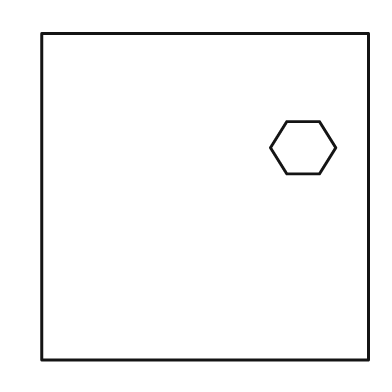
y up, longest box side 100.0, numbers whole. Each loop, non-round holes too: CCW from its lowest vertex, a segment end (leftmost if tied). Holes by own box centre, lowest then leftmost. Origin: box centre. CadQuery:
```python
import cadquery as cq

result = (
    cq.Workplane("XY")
    .moveTo(-50.0, -50.0)
    .lineTo(50.0, -50.0)
    .lineTo(50.0, 50.0)
    .lineTo(-50.0, 50.0)
    .close()
    .moveTo(25.0, 7.0)
    .lineTo(35.0, 7.0)
    .lineTo(40.0, 15.0)
    .lineTo(35.0, 23.0)
    .lineTo(25.0, 23.0)
    .lineTo(20.0, 15.0)
    .close()
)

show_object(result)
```